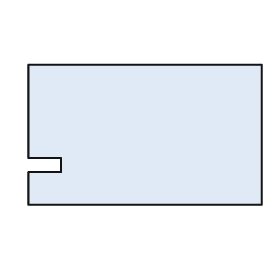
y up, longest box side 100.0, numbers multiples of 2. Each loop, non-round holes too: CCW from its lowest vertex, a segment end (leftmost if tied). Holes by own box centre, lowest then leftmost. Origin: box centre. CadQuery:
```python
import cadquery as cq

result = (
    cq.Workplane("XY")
    .moveTo(-50.0, -30.0)
    .lineTo(50.0, -30.0)
    .lineTo(50.0, 30.0)
    .lineTo(-50.0, 30.0)
    .lineTo(-50.0, -10.0)
    .lineTo(-36.0, -10.0)
    .lineTo(-36.0, -16.0)
    .lineTo(-50.0, -16.0)
    .close()
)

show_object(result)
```